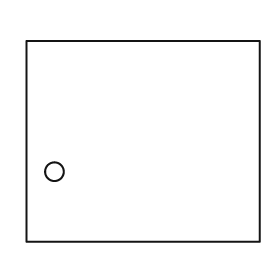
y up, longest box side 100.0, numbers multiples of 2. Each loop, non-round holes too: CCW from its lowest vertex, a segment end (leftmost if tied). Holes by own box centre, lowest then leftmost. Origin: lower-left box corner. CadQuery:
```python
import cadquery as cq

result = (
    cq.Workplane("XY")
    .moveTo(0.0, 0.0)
    .lineTo(100.0, 0.0)
    .lineTo(100.0, 86.0)
    .lineTo(0.0, 86.0)
    .close()
    .moveTo(12.0, 30.0)
    .circle(4.0)
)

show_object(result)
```